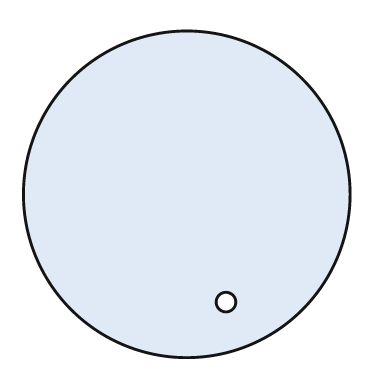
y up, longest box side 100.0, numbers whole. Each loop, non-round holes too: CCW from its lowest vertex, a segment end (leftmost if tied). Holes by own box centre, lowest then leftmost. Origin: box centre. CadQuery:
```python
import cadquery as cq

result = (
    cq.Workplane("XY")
    .moveTo(0.0, 0.0)
    .circle(50.0)
    .moveTo(12.0, -33.0)
    .circle(3.0)
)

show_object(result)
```